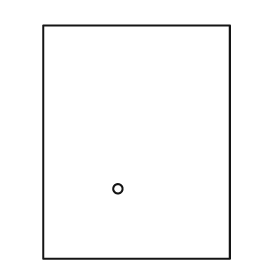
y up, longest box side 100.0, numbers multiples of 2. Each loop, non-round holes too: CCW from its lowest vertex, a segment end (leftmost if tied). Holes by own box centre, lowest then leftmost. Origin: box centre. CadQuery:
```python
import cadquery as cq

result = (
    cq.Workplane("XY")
    .moveTo(-40.0, -50.0)
    .lineTo(40.0, -50.0)
    .lineTo(40.0, 50.0)
    .lineTo(-40.0, 50.0)
    .close()
    .moveTo(-8.0, -20.0)
    .circle(2.0)
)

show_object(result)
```